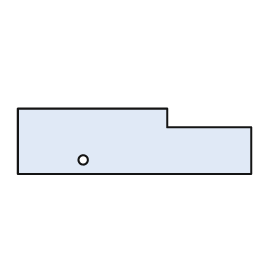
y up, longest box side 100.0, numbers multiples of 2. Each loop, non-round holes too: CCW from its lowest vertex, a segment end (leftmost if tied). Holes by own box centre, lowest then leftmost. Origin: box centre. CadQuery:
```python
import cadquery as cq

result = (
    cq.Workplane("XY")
    .moveTo(-50.0, -14.0)
    .lineTo(50.0, -14.0)
    .lineTo(50.0, 6.0)
    .lineTo(14.0, 6.0)
    .lineTo(14.0, 14.0)
    .lineTo(-50.0, 14.0)
    .close()
    .moveTo(-22.0, -8.0)
    .circle(2.0)
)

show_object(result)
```